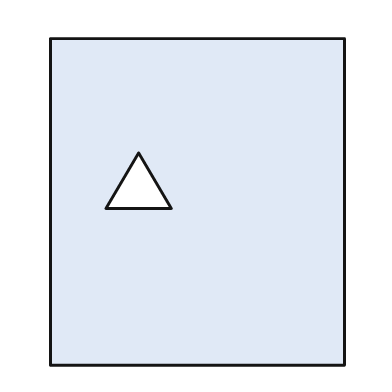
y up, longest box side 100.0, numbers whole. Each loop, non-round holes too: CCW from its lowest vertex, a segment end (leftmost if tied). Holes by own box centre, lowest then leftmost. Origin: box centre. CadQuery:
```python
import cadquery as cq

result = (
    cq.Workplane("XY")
    .moveTo(-45.0, -50.0)
    .lineTo(45.0, -50.0)
    .lineTo(45.0, 50.0)
    .lineTo(-45.0, 50.0)
    .close()
    .moveTo(-28.0, -2.0)
    .lineTo(-8.0, -2.0)
    .lineTo(-18.0, 15.0)
    .close()
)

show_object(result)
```